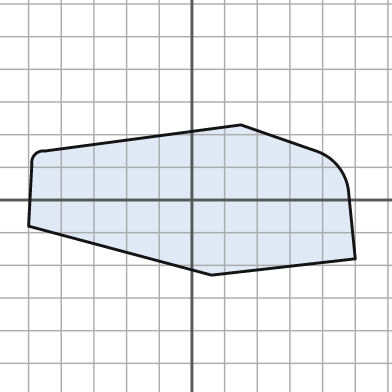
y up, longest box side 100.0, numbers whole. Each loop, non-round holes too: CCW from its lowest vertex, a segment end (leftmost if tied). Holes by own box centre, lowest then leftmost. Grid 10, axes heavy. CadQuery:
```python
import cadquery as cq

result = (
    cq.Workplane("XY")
    .moveTo(6.0, -23.0)
    .lineTo(50.0, -18.0)
    .lineTo(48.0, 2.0)
    .threePointArc((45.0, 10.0), (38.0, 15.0))
    .lineTo(15.0, 23.0)
    .lineTo(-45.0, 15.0)
    .threePointArc((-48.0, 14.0), (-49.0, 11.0))
    .lineTo(-50.0, -8.0)
    .close()
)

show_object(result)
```